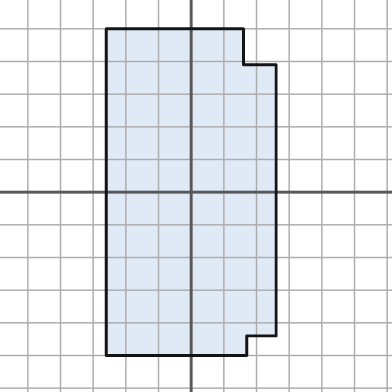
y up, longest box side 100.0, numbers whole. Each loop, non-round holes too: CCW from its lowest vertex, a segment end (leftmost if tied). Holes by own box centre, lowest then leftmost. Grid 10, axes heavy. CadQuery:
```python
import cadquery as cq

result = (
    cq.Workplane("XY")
    .moveTo(-26.0, -50.0)
    .lineTo(17.0, -50.0)
    .lineTo(17.0, -44.0)
    .lineTo(26.0, -44.0)
    .lineTo(26.0, 39.0)
    .lineTo(16.0, 39.0)
    .lineTo(16.0, 50.0)
    .lineTo(-26.0, 50.0)
    .close()
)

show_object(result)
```